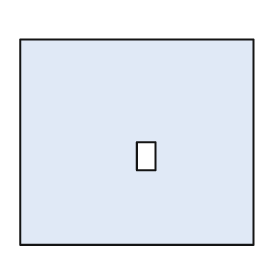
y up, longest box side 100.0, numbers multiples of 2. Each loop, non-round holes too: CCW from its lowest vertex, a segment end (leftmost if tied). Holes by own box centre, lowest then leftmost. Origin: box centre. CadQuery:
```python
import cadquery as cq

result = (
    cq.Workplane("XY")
    .moveTo(-50.0, -44.0)
    .lineTo(50.0, -44.0)
    .lineTo(50.0, 44.0)
    .lineTo(-50.0, 44.0)
    .close()
    .moveTo(0.0, -12.0)
    .lineTo(8.0, -12.0)
    .lineTo(8.0, 0.0)
    .lineTo(0.0, 0.0)
    .close()
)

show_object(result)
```